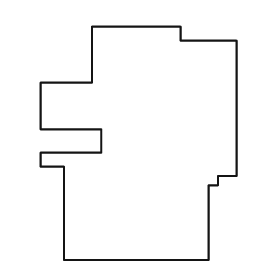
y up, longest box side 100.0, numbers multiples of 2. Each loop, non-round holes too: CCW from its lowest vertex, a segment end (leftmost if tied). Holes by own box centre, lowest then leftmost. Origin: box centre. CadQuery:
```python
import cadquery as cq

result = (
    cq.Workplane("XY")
    .moveTo(-32.0, -50.0)
    .lineTo(30.0, -50.0)
    .lineTo(30.0, -18.0)
    .lineTo(34.0, -18.0)
    .lineTo(34.0, -14.0)
    .lineTo(42.0, -14.0)
    .lineTo(42.0, 44.0)
    .lineTo(18.0, 44.0)
    .lineTo(18.0, 50.0)
    .lineTo(-20.0, 50.0)
    .lineTo(-20.0, 26.0)
    .lineTo(-42.0, 26.0)
    .lineTo(-42.0, 6.0)
    .lineTo(-16.0, 6.0)
    .lineTo(-16.0, -4.0)
    .lineTo(-42.0, -4.0)
    .lineTo(-42.0, -10.0)
    .lineTo(-32.0, -10.0)
    .close()
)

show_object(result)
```